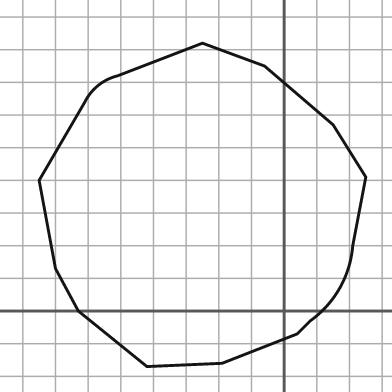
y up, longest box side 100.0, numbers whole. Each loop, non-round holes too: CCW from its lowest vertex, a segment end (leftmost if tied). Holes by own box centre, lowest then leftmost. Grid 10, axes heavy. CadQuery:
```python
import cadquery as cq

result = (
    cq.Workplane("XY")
    .moveTo(-42.0, -17.0)
    .lineTo(-19.0, -16.0)
    .lineTo(4.0, -7.0)
    .lineTo(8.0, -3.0)
    .threePointArc((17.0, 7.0), (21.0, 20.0))
    .lineTo(25.0, 41.0)
    .lineTo(15.0, 57.0)
    .lineTo(-6.0, 75.0)
    .lineTo(-25.0, 82.0)
    .lineTo(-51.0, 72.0)
    .threePointArc((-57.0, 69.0), (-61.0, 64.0))
    .lineTo(-75.0, 40.0)
    .lineTo(-70.0, 13.0)
    .lineTo(-63.0, 0.0)
    .close()
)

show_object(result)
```